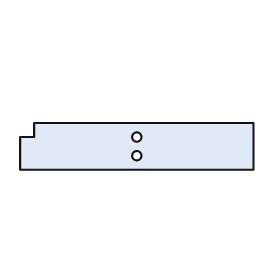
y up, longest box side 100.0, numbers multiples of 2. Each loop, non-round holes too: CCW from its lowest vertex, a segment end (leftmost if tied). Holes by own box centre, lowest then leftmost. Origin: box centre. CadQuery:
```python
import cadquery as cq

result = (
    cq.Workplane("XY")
    .moveTo(-50.0, -10.0)
    .lineTo(50.0, -10.0)
    .lineTo(50.0, 10.0)
    .lineTo(-44.0, 10.0)
    .lineTo(-44.0, 4.0)
    .lineTo(-50.0, 4.0)
    .close()
    .moveTo(0.0, -4.0)
    .circle(2.0)
    .moveTo(0.0, 4.0)
    .circle(2.0)
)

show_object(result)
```